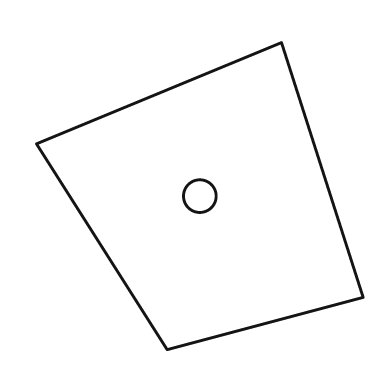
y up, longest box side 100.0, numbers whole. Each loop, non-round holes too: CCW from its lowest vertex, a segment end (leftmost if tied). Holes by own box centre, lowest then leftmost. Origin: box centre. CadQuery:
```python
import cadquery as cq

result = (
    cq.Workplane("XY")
    .moveTo(-10.0, -47.0)
    .lineTo(50.0, -31.0)
    .lineTo(25.0, 47.0)
    .lineTo(-50.0, 16.0)
    .close()
    .moveTo(0.0, 0.0)
    .circle(5.0)
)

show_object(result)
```